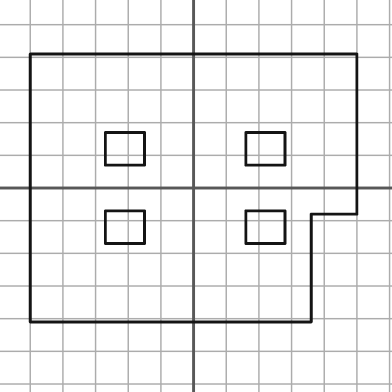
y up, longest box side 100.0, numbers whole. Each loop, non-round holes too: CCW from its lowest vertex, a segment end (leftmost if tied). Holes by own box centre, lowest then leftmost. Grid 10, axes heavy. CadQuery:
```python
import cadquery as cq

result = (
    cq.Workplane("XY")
    .moveTo(-50.0, -41.0)
    .lineTo(36.0, -41.0)
    .lineTo(36.0, -8.0)
    .lineTo(50.0, -8.0)
    .lineTo(50.0, 41.0)
    .lineTo(-50.0, 41.0)
    .close()
    .moveTo(-27.0, -17.0)
    .lineTo(-15.0, -17.0)
    .lineTo(-15.0, -7.0)
    .lineTo(-27.0, -7.0)
    .close()
    .moveTo(16.0, -17.0)
    .lineTo(28.0, -17.0)
    .lineTo(28.0, -7.0)
    .lineTo(16.0, -7.0)
    .close()
    .moveTo(-27.0, 7.0)
    .lineTo(-15.0, 7.0)
    .lineTo(-15.0, 17.0)
    .lineTo(-27.0, 17.0)
    .close()
    .moveTo(16.0, 7.0)
    .lineTo(28.0, 7.0)
    .lineTo(28.0, 17.0)
    .lineTo(16.0, 17.0)
    .close()
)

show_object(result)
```